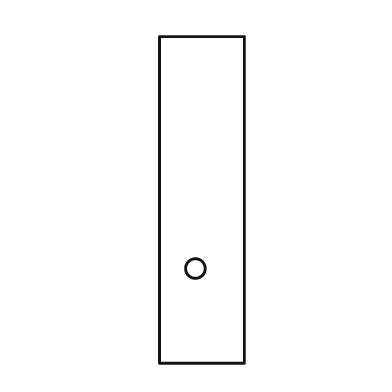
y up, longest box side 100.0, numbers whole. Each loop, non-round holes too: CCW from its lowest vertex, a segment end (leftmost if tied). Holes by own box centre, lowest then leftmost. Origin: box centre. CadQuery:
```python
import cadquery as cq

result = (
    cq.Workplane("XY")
    .moveTo(-13.0, -50.0)
    .lineTo(13.0, -50.0)
    .lineTo(13.0, 50.0)
    .lineTo(-13.0, 50.0)
    .close()
    .moveTo(-2.0, -21.0)
    .circle(3.0)
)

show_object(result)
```